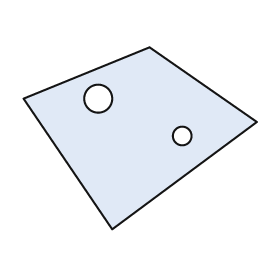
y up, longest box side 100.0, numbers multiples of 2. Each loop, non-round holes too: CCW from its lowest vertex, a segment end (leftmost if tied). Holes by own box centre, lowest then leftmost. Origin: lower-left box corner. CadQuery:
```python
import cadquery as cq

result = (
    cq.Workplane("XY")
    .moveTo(38.0, 0.0)
    .lineTo(100.0, 46.0)
    .lineTo(54.0, 78.0)
    .lineTo(0.0, 56.0)
    .close()
    .moveTo(68.0, 40.0)
    .circle(4.0)
    .moveTo(32.0, 56.0)
    .circle(6.0)
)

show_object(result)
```